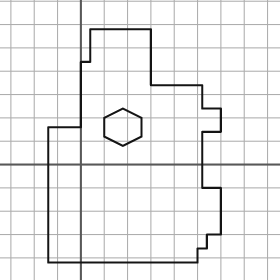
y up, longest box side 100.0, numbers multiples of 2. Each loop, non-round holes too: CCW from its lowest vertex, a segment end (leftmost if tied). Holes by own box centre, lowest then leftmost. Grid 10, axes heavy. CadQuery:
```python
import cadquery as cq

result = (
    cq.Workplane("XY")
    .moveTo(-14.0, -42.0)
    .lineTo(50.0, -42.0)
    .lineTo(50.0, -36.0)
    .lineTo(54.0, -36.0)
    .lineTo(54.0, -30.0)
    .lineTo(60.0, -30.0)
    .lineTo(60.0, -10.0)
    .lineTo(52.0, -10.0)
    .lineTo(52.0, 14.0)
    .lineTo(60.0, 14.0)
    .lineTo(60.0, 24.0)
    .lineTo(52.0, 24.0)
    .lineTo(52.0, 34.0)
    .lineTo(30.0, 34.0)
    .lineTo(30.0, 58.0)
    .lineTo(4.0, 58.0)
    .lineTo(4.0, 44.0)
    .lineTo(0.0, 44.0)
    .lineTo(0.0, 16.0)
    .lineTo(-14.0, 16.0)
    .close()
    .moveTo(18.0, 8.0)
    .lineTo(26.0, 12.0)
    .lineTo(26.0, 20.0)
    .lineTo(18.0, 24.0)
    .lineTo(10.0, 20.0)
    .lineTo(10.0, 12.0)
    .close()
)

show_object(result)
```